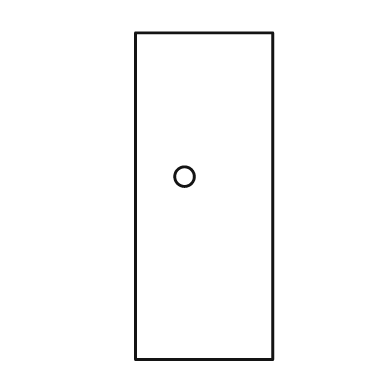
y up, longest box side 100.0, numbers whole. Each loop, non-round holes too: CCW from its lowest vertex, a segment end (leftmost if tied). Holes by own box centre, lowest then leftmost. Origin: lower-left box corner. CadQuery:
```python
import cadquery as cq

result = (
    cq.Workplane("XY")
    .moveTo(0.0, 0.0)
    .lineTo(42.0, 0.0)
    .lineTo(42.0, 100.0)
    .lineTo(0.0, 100.0)
    .close()
    .moveTo(15.0, 56.0)
    .circle(3.0)
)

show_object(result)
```